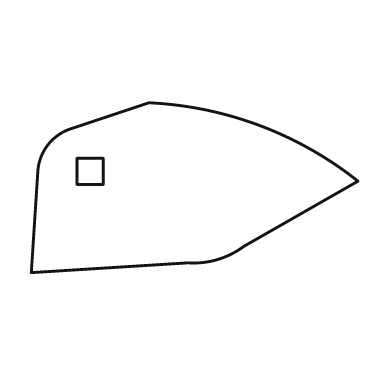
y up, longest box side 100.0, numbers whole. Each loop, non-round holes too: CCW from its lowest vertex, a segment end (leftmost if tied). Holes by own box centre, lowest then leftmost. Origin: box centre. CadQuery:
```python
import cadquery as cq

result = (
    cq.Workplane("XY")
    .moveTo(-50.0, -26.0)
    .lineTo(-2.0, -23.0)
    .threePointArc((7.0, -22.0), (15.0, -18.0))
    .lineTo(50.0, 2.0)
    .threePointArc((20.0, 19.0), (-14.0, 26.0))
    .lineTo(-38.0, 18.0)
    .threePointArc((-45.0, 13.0), (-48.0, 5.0))
    .close()
    .moveTo(-36.0, 1.0)
    .lineTo(-28.0, 1.0)
    .lineTo(-28.0, 9.0)
    .lineTo(-36.0, 9.0)
    .close()
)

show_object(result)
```